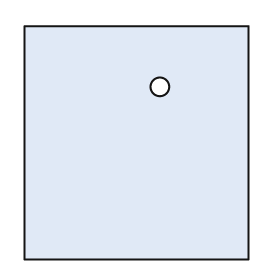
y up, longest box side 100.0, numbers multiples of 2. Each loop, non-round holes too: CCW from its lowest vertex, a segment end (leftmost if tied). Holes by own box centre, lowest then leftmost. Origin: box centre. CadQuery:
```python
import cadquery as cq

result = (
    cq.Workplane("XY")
    .moveTo(-48.0, -50.0)
    .lineTo(48.0, -50.0)
    .lineTo(48.0, 50.0)
    .lineTo(-48.0, 50.0)
    .close()
    .moveTo(10.0, 24.0)
    .circle(4.0)
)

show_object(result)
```